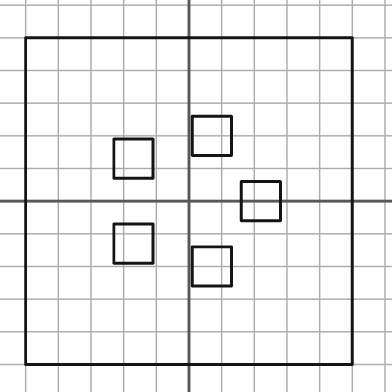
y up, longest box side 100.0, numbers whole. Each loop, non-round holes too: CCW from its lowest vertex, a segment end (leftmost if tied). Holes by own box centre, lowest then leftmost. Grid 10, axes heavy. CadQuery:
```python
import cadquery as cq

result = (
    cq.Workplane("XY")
    .moveTo(-50.0, -50.0)
    .lineTo(50.0, -50.0)
    .lineTo(50.0, 50.0)
    .lineTo(-50.0, 50.0)
    .close()
    .moveTo(1.0, -26.0)
    .lineTo(13.0, -26.0)
    .lineTo(13.0, -14.0)
    .lineTo(1.0, -14.0)
    .close()
    .moveTo(-23.0, -19.0)
    .lineTo(-11.0, -19.0)
    .lineTo(-11.0, -7.0)
    .lineTo(-23.0, -7.0)
    .close()
    .moveTo(16.0, -6.0)
    .lineTo(28.0, -6.0)
    .lineTo(28.0, 6.0)
    .lineTo(16.0, 6.0)
    .close()
    .moveTo(-23.0, 7.0)
    .lineTo(-11.0, 7.0)
    .lineTo(-11.0, 19.0)
    .lineTo(-23.0, 19.0)
    .close()
    .moveTo(1.0, 14.0)
    .lineTo(13.0, 14.0)
    .lineTo(13.0, 26.0)
    .lineTo(1.0, 26.0)
    .close()
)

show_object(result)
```